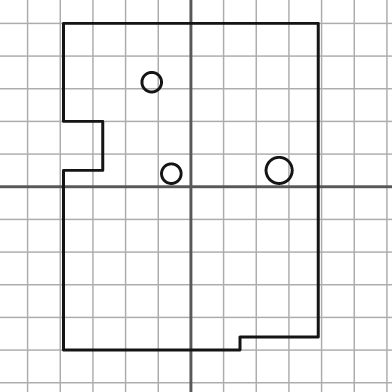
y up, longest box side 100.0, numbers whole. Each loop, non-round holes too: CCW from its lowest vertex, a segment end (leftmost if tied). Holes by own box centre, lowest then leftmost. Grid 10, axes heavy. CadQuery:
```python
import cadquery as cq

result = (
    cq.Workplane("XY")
    .moveTo(-39.0, -50.0)
    .lineTo(15.0, -50.0)
    .lineTo(15.0, -46.0)
    .lineTo(39.0, -46.0)
    .lineTo(39.0, 50.0)
    .lineTo(-39.0, 50.0)
    .lineTo(-39.0, 20.0)
    .lineTo(-27.0, 20.0)
    .lineTo(-27.0, 5.0)
    .lineTo(-39.0, 5.0)
    .close()
    .moveTo(-6.0, 4.0)
    .circle(3.0)
    .moveTo(27.0, 5.0)
    .circle(4.0)
    .moveTo(-12.0, 32.0)
    .circle(3.0)
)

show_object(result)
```